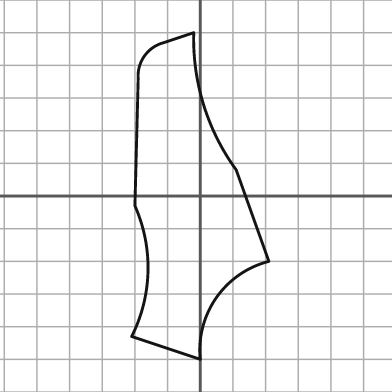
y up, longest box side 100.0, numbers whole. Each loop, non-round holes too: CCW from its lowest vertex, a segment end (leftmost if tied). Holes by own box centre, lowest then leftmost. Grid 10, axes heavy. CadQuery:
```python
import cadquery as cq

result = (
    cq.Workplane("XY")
    .moveTo(0.0, -50.0)
    .threePointArc((5.0, -31.0), (21.0, -20.0))
    .lineTo(11.0, 8.0)
    .threePointArc((1.0, 28.0), (-2.0, 50.0))
    .lineTo(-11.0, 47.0)
    .threePointArc((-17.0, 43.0), (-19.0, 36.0))
    .lineTo(-20.0, -3.0)
    .threePointArc((-16.0, -23.0), (-21.0, -43.0))
    .close()
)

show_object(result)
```